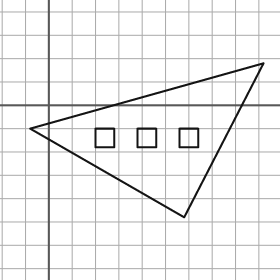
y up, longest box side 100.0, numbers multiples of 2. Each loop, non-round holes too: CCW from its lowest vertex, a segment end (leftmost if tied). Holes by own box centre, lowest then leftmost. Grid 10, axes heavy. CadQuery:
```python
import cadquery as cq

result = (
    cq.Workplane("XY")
    .moveTo(58.0, -48.0)
    .lineTo(92.0, 18.0)
    .lineTo(-8.0, -10.0)
    .close()
    .moveTo(20.0, -18.0)
    .lineTo(28.0, -18.0)
    .lineTo(28.0, -10.0)
    .lineTo(20.0, -10.0)
    .close()
    .moveTo(38.0, -18.0)
    .lineTo(46.0, -18.0)
    .lineTo(46.0, -10.0)
    .lineTo(38.0, -10.0)
    .close()
    .moveTo(56.0, -18.0)
    .lineTo(64.0, -18.0)
    .lineTo(64.0, -10.0)
    .lineTo(56.0, -10.0)
    .close()
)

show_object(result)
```